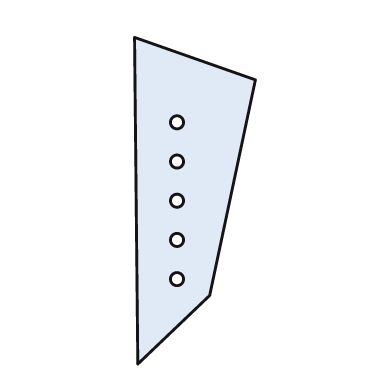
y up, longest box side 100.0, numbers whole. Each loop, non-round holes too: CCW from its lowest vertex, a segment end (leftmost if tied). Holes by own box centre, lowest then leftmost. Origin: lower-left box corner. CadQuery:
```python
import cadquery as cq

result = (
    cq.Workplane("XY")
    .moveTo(1.0, 0.0)
    .lineTo(23.0, 21.0)
    .lineTo(37.0, 87.0)
    .lineTo(0.0, 100.0)
    .close()
    .moveTo(13.0, 26.0)
    .circle(2.0)
    .moveTo(13.0, 38.0)
    .circle(2.0)
    .moveTo(13.0, 50.0)
    .circle(2.0)
    .moveTo(13.0, 62.0)
    .circle(2.0)
    .moveTo(13.0, 74.0)
    .circle(2.0)
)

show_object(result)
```